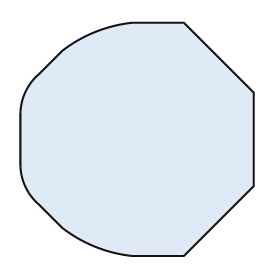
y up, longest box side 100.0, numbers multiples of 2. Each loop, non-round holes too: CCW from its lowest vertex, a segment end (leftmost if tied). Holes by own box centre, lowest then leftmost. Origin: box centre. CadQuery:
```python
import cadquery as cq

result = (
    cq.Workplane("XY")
    .moveTo(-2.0, -50.0)
    .lineTo(20.0, -50.0)
    .lineTo(50.0, -20.0)
    .lineTo(50.0, 20.0)
    .lineTo(20.0, 50.0)
    .lineTo(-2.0, 50.0)
    .threePointArc((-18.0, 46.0), (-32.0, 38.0))
    .lineTo(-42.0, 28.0)
    .threePointArc((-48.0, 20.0), (-50.0, 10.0))
    .lineTo(-50.0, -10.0)
    .threePointArc((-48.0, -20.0), (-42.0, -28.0))
    .lineTo(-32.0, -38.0)
    .threePointArc((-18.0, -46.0), (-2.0, -50.0))
    .close()
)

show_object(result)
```